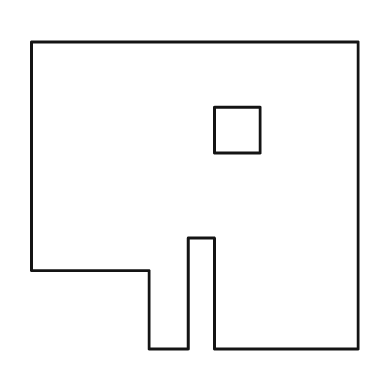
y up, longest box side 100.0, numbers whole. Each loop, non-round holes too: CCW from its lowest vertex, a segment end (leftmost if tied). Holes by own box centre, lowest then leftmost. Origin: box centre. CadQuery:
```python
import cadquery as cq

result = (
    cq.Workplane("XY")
    .moveTo(-14.0, -47.0)
    .lineTo(-2.0, -47.0)
    .lineTo(-2.0, -13.0)
    .lineTo(6.0, -13.0)
    .lineTo(6.0, -47.0)
    .lineTo(50.0, -47.0)
    .lineTo(50.0, 47.0)
    .lineTo(-50.0, 47.0)
    .lineTo(-50.0, -23.0)
    .lineTo(-14.0, -23.0)
    .close()
    .moveTo(6.0, 13.0)
    .lineTo(20.0, 13.0)
    .lineTo(20.0, 27.0)
    .lineTo(6.0, 27.0)
    .close()
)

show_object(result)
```